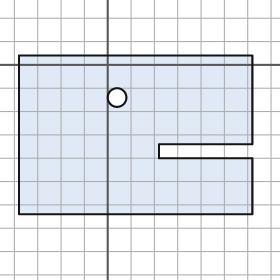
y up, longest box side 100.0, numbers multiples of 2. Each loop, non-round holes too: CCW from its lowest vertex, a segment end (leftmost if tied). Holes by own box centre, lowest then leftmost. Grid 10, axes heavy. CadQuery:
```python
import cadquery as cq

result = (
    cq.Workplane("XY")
    .moveTo(-38.0, -64.0)
    .lineTo(62.0, -64.0)
    .lineTo(62.0, -40.0)
    .lineTo(22.0, -40.0)
    .lineTo(22.0, -34.0)
    .lineTo(62.0, -34.0)
    .lineTo(62.0, 4.0)
    .lineTo(-38.0, 4.0)
    .close()
    .moveTo(4.0, -14.0)
    .circle(4.0)
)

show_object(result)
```